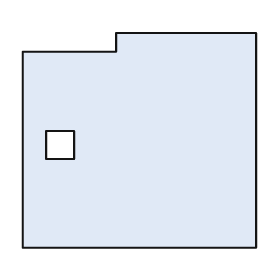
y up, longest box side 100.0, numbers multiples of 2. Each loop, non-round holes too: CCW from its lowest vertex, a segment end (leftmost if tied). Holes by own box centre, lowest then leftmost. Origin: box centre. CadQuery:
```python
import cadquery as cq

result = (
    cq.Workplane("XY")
    .moveTo(-50.0, -46.0)
    .lineTo(50.0, -46.0)
    .lineTo(50.0, 46.0)
    .lineTo(-10.0, 46.0)
    .lineTo(-10.0, 38.0)
    .lineTo(-50.0, 38.0)
    .close()
    .moveTo(-40.0, -8.0)
    .lineTo(-28.0, -8.0)
    .lineTo(-28.0, 4.0)
    .lineTo(-40.0, 4.0)
    .close()
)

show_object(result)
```